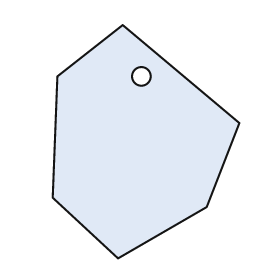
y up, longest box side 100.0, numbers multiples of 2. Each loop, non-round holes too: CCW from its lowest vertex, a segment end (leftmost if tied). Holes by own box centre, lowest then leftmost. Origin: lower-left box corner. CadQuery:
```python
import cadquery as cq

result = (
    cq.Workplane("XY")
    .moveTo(28.0, 0.0)
    .lineTo(66.0, 22.0)
    .lineTo(80.0, 58.0)
    .lineTo(30.0, 100.0)
    .lineTo(2.0, 78.0)
    .lineTo(0.0, 26.0)
    .close()
    .moveTo(38.0, 78.0)
    .circle(4.0)
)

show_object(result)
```